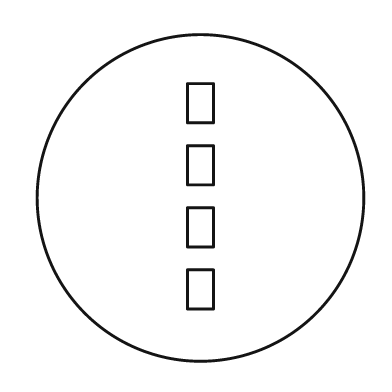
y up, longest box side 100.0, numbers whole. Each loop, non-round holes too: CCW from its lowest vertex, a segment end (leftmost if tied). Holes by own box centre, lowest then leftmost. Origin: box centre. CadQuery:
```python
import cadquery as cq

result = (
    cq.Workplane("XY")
    .moveTo(0.0, 0.0)
    .circle(50.0)
    .moveTo(-4.0, -34.0)
    .lineTo(4.0, -34.0)
    .lineTo(4.0, -22.0)
    .lineTo(-4.0, -22.0)
    .close()
    .moveTo(-4.0, -15.0)
    .lineTo(4.0, -15.0)
    .lineTo(4.0, -3.0)
    .lineTo(-4.0, -3.0)
    .close()
    .moveTo(-4.0, 4.0)
    .lineTo(4.0, 4.0)
    .lineTo(4.0, 16.0)
    .lineTo(-4.0, 16.0)
    .close()
    .moveTo(-4.0, 23.0)
    .lineTo(4.0, 23.0)
    .lineTo(4.0, 35.0)
    .lineTo(-4.0, 35.0)
    .close()
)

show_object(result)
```